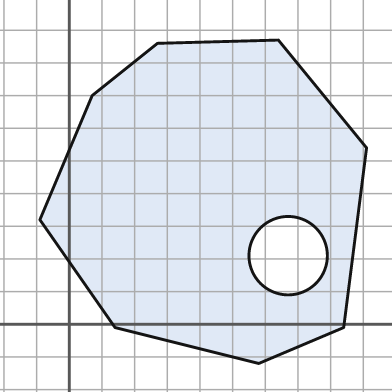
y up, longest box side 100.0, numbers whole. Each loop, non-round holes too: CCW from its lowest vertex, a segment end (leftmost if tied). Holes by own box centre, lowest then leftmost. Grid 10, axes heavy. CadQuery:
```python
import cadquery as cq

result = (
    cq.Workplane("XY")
    .moveTo(58.0, -12.0)
    .lineTo(84.0, -1.0)
    .lineTo(91.0, 54.0)
    .lineTo(64.0, 87.0)
    .lineTo(27.0, 86.0)
    .lineTo(7.0, 70.0)
    .lineTo(-9.0, 32.0)
    .lineTo(14.0, -1.0)
    .close()
    .moveTo(67.0, 21.0)
    .circle(12.0)
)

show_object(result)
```